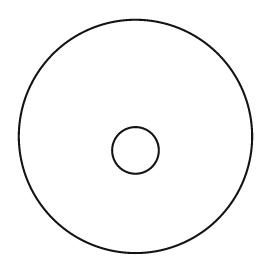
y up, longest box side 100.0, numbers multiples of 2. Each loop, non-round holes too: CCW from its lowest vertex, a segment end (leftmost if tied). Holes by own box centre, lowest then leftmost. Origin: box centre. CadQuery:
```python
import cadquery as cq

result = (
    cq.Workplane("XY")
    .moveTo(0.0, 0.0)
    .circle(50.0)
    .moveTo(0.0, -6.0)
    .circle(10.0)
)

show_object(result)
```